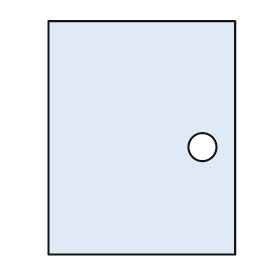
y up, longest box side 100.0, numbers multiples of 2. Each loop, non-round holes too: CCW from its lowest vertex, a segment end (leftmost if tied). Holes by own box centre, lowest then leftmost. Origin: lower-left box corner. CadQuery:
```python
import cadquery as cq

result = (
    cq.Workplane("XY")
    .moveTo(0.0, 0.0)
    .lineTo(80.0, 0.0)
    .lineTo(80.0, 100.0)
    .lineTo(0.0, 100.0)
    .close()
    .moveTo(66.0, 46.0)
    .circle(6.0)
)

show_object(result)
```